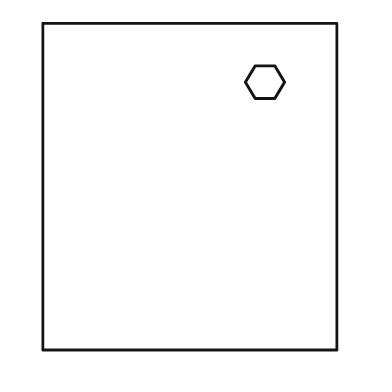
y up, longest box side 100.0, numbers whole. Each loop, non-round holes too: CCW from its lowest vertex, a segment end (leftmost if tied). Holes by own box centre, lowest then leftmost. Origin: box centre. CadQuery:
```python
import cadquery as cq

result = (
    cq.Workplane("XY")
    .moveTo(-45.0, -50.0)
    .lineTo(45.0, -50.0)
    .lineTo(45.0, 50.0)
    .lineTo(-45.0, 50.0)
    .close()
    .moveTo(20.0, 27.0)
    .lineTo(26.0, 27.0)
    .lineTo(29.0, 32.0)
    .lineTo(26.0, 37.0)
    .lineTo(20.0, 37.0)
    .lineTo(17.0, 32.0)
    .close()
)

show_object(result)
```